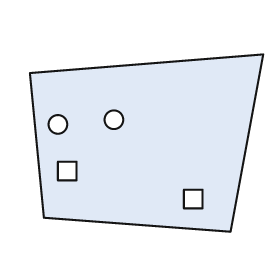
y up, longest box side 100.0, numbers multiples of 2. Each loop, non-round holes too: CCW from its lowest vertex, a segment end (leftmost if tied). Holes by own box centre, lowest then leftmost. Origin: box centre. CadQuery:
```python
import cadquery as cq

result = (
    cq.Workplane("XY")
    .moveTo(36.0, -38.0)
    .lineTo(50.0, 38.0)
    .lineTo(-50.0, 30.0)
    .lineTo(-44.0, -32.0)
    .close()
    .moveTo(16.0, -28.0)
    .lineTo(24.0, -28.0)
    .lineTo(24.0, -20.0)
    .lineTo(16.0, -20.0)
    .close()
    .moveTo(-38.0, -16.0)
    .lineTo(-30.0, -16.0)
    .lineTo(-30.0, -8.0)
    .lineTo(-38.0, -8.0)
    .close()
    .moveTo(-38.0, 8.0)
    .circle(4.0)
    .moveTo(-14.0, 10.0)
    .circle(4.0)
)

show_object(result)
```